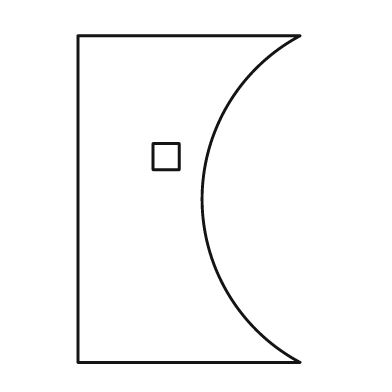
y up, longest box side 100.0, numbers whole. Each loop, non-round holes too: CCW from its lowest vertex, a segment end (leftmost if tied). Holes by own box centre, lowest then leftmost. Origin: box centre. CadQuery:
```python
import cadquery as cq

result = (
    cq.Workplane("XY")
    .moveTo(-34.0, -50.0)
    .lineTo(34.0, -50.0)
    .threePointArc((4.0, 0.0), (34.0, 50.0))
    .lineTo(-34.0, 50.0)
    .close()
    .moveTo(-11.0, 9.0)
    .lineTo(-3.0, 9.0)
    .lineTo(-3.0, 17.0)
    .lineTo(-11.0, 17.0)
    .close()
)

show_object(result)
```